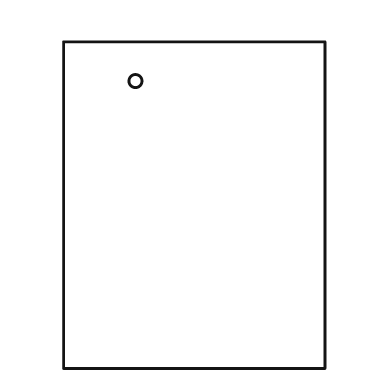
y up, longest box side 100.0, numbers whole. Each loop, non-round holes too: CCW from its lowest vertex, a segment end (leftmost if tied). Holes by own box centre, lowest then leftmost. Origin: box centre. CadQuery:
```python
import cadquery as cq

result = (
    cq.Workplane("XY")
    .moveTo(-40.0, -50.0)
    .lineTo(40.0, -50.0)
    .lineTo(40.0, 50.0)
    .lineTo(-40.0, 50.0)
    .close()
    .moveTo(-18.0, 38.0)
    .circle(2.0)
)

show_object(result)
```